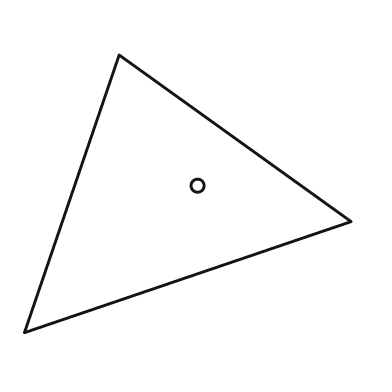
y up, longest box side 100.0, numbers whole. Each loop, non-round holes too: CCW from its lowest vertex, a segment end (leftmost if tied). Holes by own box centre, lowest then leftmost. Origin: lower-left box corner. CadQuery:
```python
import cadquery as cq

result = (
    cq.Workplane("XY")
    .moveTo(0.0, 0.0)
    .lineTo(100.0, 34.0)
    .lineTo(29.0, 85.0)
    .close()
    .moveTo(53.0, 45.0)
    .circle(2.0)
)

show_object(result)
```